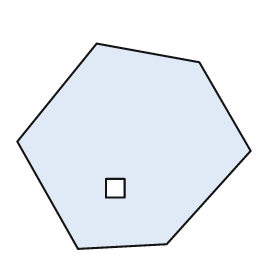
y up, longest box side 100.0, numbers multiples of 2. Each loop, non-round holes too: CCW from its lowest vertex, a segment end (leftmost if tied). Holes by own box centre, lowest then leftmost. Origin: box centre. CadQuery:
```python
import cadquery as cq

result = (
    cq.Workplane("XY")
    .moveTo(-24.0, -44.0)
    .lineTo(14.0, -42.0)
    .lineTo(50.0, -2.0)
    .lineTo(28.0, 36.0)
    .lineTo(-16.0, 44.0)
    .lineTo(-50.0, 2.0)
    .close()
    .moveTo(-12.0, -22.0)
    .lineTo(-4.0, -22.0)
    .lineTo(-4.0, -14.0)
    .lineTo(-12.0, -14.0)
    .close()
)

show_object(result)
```